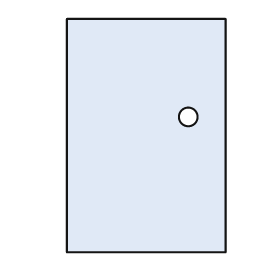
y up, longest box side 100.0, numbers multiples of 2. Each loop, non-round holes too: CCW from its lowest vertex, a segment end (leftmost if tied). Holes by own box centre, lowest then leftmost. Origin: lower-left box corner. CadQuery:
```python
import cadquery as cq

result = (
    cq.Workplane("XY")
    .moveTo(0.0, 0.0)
    .lineTo(68.0, 0.0)
    .lineTo(68.0, 100.0)
    .lineTo(0.0, 100.0)
    .close()
    .moveTo(52.0, 58.0)
    .circle(4.0)
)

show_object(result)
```